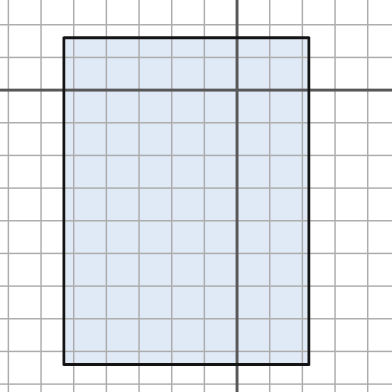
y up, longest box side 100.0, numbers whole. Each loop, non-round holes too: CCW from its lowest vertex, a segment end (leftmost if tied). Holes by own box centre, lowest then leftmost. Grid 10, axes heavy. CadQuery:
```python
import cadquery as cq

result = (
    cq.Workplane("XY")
    .moveTo(-53.0, -84.0)
    .lineTo(22.0, -84.0)
    .lineTo(22.0, 16.0)
    .lineTo(-53.0, 16.0)
    .close()
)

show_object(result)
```